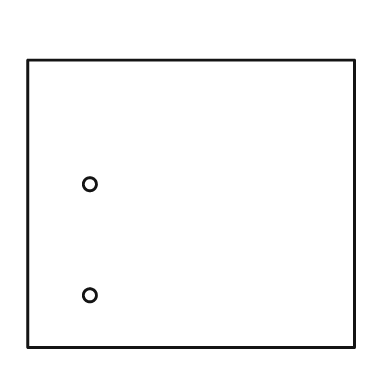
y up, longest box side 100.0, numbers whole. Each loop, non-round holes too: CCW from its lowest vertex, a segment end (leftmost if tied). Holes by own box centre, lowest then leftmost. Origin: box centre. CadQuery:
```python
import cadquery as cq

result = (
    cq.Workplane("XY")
    .moveTo(-50.0, -44.0)
    .lineTo(50.0, -44.0)
    .lineTo(50.0, 44.0)
    .lineTo(-50.0, 44.0)
    .close()
    .moveTo(-31.0, -28.0)
    .circle(2.0)
    .moveTo(-31.0, 6.0)
    .circle(2.0)
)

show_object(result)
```